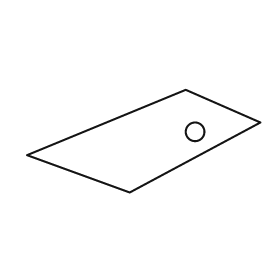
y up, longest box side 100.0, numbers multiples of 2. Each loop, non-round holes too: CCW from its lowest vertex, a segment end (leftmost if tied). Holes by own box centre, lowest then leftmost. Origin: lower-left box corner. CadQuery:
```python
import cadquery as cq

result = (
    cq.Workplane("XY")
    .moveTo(44.0, 0.0)
    .lineTo(100.0, 30.0)
    .lineTo(68.0, 44.0)
    .lineTo(0.0, 16.0)
    .close()
    .moveTo(72.0, 26.0)
    .circle(4.0)
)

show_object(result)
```